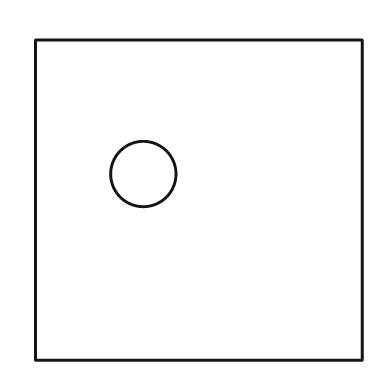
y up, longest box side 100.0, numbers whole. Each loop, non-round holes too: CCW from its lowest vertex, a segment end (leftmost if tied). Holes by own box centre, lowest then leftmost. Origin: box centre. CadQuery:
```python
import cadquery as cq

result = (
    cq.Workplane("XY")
    .moveTo(-50.0, -49.0)
    .lineTo(50.0, -49.0)
    .lineTo(50.0, 49.0)
    .lineTo(-50.0, 49.0)
    .close()
    .moveTo(-17.0, 8.0)
    .circle(10.0)
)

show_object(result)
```